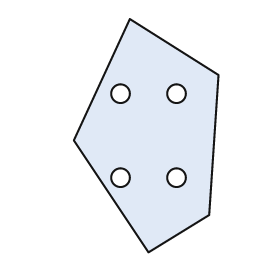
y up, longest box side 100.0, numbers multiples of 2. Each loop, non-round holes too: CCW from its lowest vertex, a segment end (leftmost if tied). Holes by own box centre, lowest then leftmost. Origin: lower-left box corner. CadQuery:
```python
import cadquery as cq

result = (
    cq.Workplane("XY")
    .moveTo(32.0, 0.0)
    .lineTo(58.0, 16.0)
    .lineTo(62.0, 76.0)
    .lineTo(24.0, 100.0)
    .lineTo(0.0, 48.0)
    .close()
    .moveTo(20.0, 32.0)
    .circle(4.0)
    .moveTo(44.0, 32.0)
    .circle(4.0)
    .moveTo(20.0, 68.0)
    .circle(4.0)
    .moveTo(44.0, 68.0)
    .circle(4.0)
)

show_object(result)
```